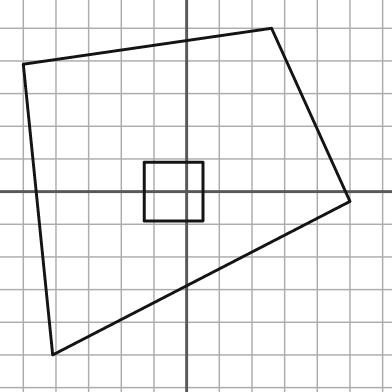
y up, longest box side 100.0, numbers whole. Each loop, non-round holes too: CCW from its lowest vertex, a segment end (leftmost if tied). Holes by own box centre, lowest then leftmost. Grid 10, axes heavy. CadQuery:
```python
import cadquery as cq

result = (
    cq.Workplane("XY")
    .moveTo(-41.0, -50.0)
    .lineTo(50.0, -3.0)
    .lineTo(26.0, 50.0)
    .lineTo(-50.0, 39.0)
    .close()
    .moveTo(-13.0, -9.0)
    .lineTo(5.0, -9.0)
    .lineTo(5.0, 9.0)
    .lineTo(-13.0, 9.0)
    .close()
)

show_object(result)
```